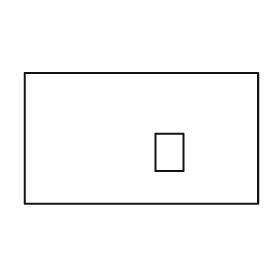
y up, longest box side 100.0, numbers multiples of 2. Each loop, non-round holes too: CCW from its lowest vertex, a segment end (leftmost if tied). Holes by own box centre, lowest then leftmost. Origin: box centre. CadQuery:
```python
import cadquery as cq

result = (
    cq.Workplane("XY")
    .moveTo(-50.0, -28.0)
    .lineTo(50.0, -28.0)
    .lineTo(50.0, 28.0)
    .lineTo(-50.0, 28.0)
    .close()
    .moveTo(6.0, -14.0)
    .lineTo(18.0, -14.0)
    .lineTo(18.0, 2.0)
    .lineTo(6.0, 2.0)
    .close()
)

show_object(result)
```